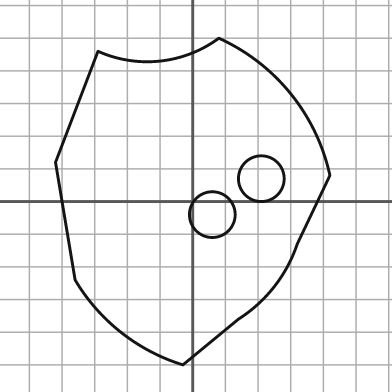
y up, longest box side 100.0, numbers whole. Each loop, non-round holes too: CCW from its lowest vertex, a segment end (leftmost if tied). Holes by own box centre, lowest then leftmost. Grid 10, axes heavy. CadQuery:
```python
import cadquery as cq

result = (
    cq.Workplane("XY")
    .moveTo(-3.0, -50.0)
    .lineTo(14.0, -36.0)
    .threePointArc((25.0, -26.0), (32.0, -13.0))
    .lineTo(42.0, 8.0)
    .threePointArc((30.0, 33.0), (8.0, 50.0))
    .threePointArc((-10.0, 43.0), (-29.0, 46.0))
    .lineTo(-42.0, 12.0)
    .lineTo(-36.0, -24.0)
    .threePointArc((-22.0, -40.0), (-3.0, -50.0))
    .close()
    .moveTo(6.0, -4.0)
    .circle(7.0)
    .moveTo(21.0, 7.0)
    .circle(7.0)
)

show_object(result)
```